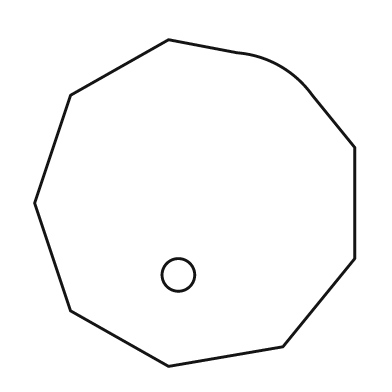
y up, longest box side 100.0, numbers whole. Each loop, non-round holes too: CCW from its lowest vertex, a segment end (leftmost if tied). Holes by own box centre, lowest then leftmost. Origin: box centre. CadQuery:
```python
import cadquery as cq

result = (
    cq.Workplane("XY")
    .moveTo(-8.0, -50.0)
    .lineTo(27.0, -44.0)
    .lineTo(49.0, -17.0)
    .lineTo(49.0, 17.0)
    .lineTo(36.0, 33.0)
    .threePointArc((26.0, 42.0), (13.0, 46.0))
    .lineTo(-8.0, 50.0)
    .lineTo(-38.0, 33.0)
    .lineTo(-49.0, 0.0)
    .lineTo(-38.0, -33.0)
    .close()
    .moveTo(-5.0, -22.0)
    .circle(5.0)
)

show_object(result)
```